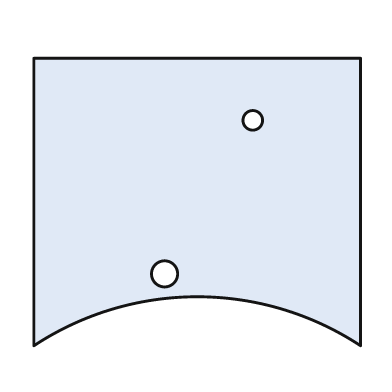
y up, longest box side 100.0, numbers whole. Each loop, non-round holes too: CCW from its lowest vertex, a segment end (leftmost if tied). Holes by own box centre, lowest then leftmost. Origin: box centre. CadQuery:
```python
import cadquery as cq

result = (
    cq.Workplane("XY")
    .moveTo(-50.0, -44.0)
    .threePointArc((0.0, -29.0), (50.0, -44.0))
    .lineTo(50.0, 44.0)
    .lineTo(-50.0, 44.0)
    .close()
    .moveTo(-10.0, -22.0)
    .circle(4.0)
    .moveTo(17.0, 25.0)
    .circle(3.0)
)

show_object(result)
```